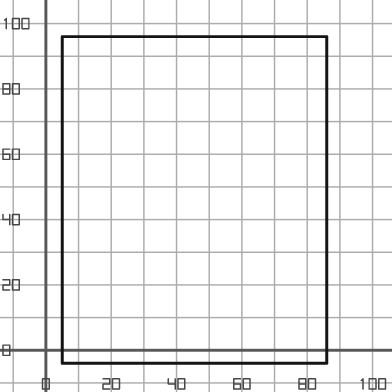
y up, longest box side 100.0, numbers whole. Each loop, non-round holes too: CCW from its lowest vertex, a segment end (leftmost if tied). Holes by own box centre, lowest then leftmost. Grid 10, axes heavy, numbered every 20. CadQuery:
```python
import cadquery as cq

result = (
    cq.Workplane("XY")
    .moveTo(5.0, -4.0)
    .lineTo(86.0, -4.0)
    .lineTo(86.0, 96.0)
    .lineTo(5.0, 96.0)
    .close()
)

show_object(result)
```